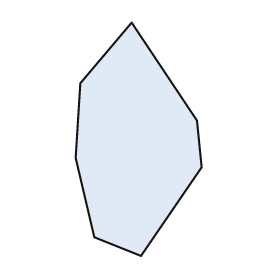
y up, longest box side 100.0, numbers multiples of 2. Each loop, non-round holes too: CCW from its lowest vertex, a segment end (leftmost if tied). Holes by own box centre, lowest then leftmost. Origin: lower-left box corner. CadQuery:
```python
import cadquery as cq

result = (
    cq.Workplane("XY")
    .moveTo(28.0, 0.0)
    .lineTo(54.0, 38.0)
    .lineTo(52.0, 58.0)
    .lineTo(24.0, 100.0)
    .lineTo(2.0, 74.0)
    .lineTo(0.0, 42.0)
    .lineTo(8.0, 8.0)
    .close()
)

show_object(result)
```